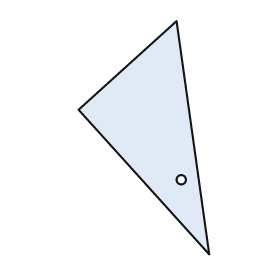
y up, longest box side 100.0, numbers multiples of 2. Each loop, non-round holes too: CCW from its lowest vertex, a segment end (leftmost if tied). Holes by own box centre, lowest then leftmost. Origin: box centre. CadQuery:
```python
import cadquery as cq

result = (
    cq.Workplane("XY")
    .moveTo(28.0, -50.0)
    .lineTo(14.0, 50.0)
    .lineTo(-28.0, 12.0)
    .close()
    .moveTo(16.0, -18.0)
    .circle(2.0)
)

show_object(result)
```